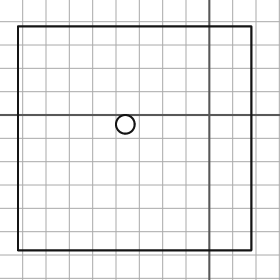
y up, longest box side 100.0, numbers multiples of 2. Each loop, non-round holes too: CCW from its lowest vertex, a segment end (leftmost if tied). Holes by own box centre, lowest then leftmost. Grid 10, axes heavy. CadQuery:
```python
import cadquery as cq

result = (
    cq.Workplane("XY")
    .moveTo(-82.0, -58.0)
    .lineTo(18.0, -58.0)
    .lineTo(18.0, 38.0)
    .lineTo(-82.0, 38.0)
    .close()
    .moveTo(-36.0, -4.0)
    .circle(4.0)
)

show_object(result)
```